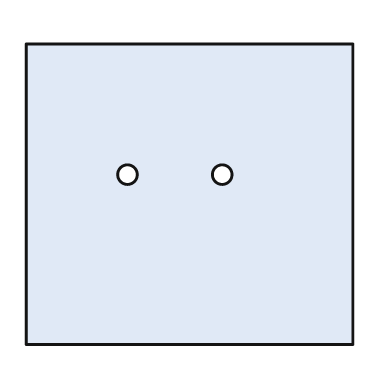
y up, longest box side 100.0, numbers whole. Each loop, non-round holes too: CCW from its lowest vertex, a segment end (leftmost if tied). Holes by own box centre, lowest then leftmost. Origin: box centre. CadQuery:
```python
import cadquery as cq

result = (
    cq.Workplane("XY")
    .moveTo(-50.0, -46.0)
    .lineTo(50.0, -46.0)
    .lineTo(50.0, 46.0)
    .lineTo(-50.0, 46.0)
    .close()
    .moveTo(-19.0, 6.0)
    .circle(3.0)
    .moveTo(10.0, 6.0)
    .circle(3.0)
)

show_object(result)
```